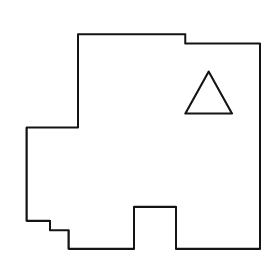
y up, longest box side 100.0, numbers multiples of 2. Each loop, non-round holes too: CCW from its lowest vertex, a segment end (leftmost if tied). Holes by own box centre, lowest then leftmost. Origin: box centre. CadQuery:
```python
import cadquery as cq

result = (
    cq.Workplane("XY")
    .moveTo(-32.0, -46.0)
    .lineTo(-4.0, -46.0)
    .lineTo(-4.0, -28.0)
    .lineTo(14.0, -28.0)
    .lineTo(14.0, -46.0)
    .lineTo(50.0, -46.0)
    .lineTo(50.0, 42.0)
    .lineTo(18.0, 42.0)
    .lineTo(18.0, 46.0)
    .lineTo(-28.0, 46.0)
    .lineTo(-28.0, 6.0)
    .lineTo(-50.0, 6.0)
    .lineTo(-50.0, -34.0)
    .lineTo(-40.0, -34.0)
    .lineTo(-40.0, -38.0)
    .lineTo(-32.0, -38.0)
    .close()
    .moveTo(18.0, 12.0)
    .lineTo(38.0, 12.0)
    .lineTo(28.0, 30.0)
    .close()
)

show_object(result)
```